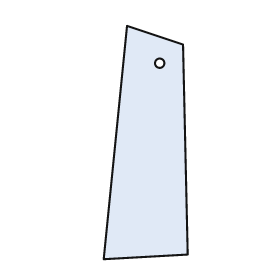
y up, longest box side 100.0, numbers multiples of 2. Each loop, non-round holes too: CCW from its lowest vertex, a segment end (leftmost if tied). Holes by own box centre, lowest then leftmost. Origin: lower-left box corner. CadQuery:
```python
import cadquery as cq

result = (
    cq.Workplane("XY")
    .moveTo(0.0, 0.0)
    .lineTo(36.0, 2.0)
    .lineTo(34.0, 92.0)
    .lineTo(10.0, 100.0)
    .close()
    .moveTo(24.0, 84.0)
    .circle(2.0)
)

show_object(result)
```